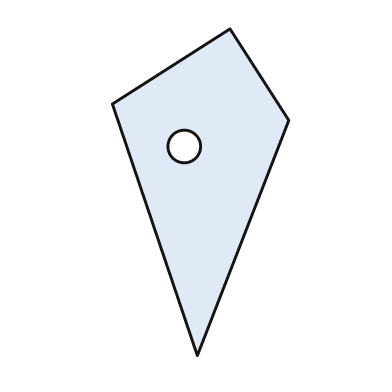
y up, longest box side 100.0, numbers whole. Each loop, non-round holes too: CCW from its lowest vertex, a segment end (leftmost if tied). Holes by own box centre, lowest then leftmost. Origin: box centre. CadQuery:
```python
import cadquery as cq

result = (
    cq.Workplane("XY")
    .moveTo(-1.0, -50.0)
    .lineTo(27.0, 22.0)
    .lineTo(9.0, 50.0)
    .lineTo(-27.0, 27.0)
    .close()
    .moveTo(-5.0, 14.0)
    .circle(5.0)
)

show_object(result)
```